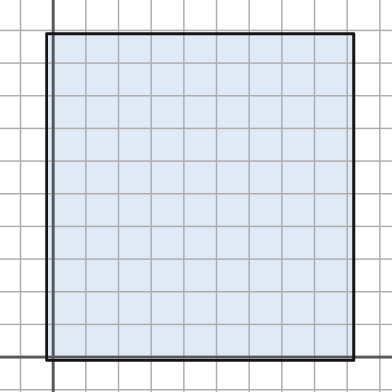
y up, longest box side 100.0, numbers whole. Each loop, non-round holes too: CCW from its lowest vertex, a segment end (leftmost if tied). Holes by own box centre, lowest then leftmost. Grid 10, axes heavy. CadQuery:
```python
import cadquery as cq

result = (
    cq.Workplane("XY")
    .moveTo(-2.0, -1.0)
    .lineTo(92.0, -1.0)
    .lineTo(92.0, 99.0)
    .lineTo(-2.0, 99.0)
    .close()
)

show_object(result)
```